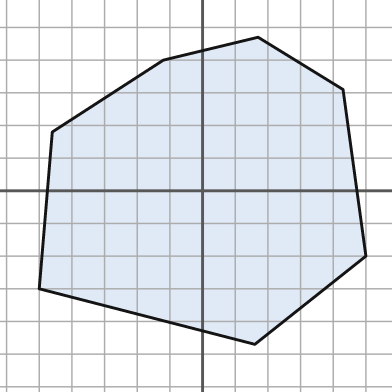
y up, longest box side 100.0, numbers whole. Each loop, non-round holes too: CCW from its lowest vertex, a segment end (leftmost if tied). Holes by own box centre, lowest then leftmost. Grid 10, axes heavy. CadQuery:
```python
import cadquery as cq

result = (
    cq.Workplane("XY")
    .moveTo(16.0, -47.0)
    .lineTo(50.0, -20.0)
    .lineTo(43.0, 31.0)
    .lineTo(17.0, 47.0)
    .lineTo(-12.0, 40.0)
    .lineTo(-46.0, 18.0)
    .lineTo(-50.0, -30.0)
    .close()
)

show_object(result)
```